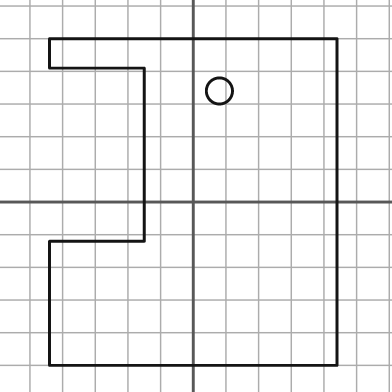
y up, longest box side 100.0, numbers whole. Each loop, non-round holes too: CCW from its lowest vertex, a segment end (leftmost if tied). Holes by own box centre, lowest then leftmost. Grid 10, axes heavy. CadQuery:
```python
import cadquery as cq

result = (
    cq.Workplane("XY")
    .moveTo(-44.0, -50.0)
    .lineTo(44.0, -50.0)
    .lineTo(44.0, 50.0)
    .lineTo(-44.0, 50.0)
    .lineTo(-44.0, 41.0)
    .lineTo(-15.0, 41.0)
    .lineTo(-15.0, -12.0)
    .lineTo(-44.0, -12.0)
    .close()
    .moveTo(8.0, 34.0)
    .circle(4.0)
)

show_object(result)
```